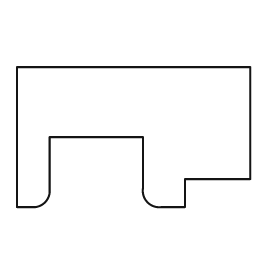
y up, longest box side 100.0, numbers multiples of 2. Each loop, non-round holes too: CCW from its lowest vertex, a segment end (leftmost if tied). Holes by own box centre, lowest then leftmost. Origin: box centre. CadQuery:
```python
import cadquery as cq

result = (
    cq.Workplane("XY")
    .moveTo(-50.0, -30.0)
    .lineTo(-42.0, -30.0)
    .threePointArc((-38.0, -28.0), (-36.0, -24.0))
    .lineTo(-36.0, 0.0)
    .lineTo(4.0, 0.0)
    .lineTo(4.0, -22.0)
    .threePointArc((6.0, -28.0), (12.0, -30.0))
    .lineTo(22.0, -30.0)
    .lineTo(22.0, -18.0)
    .lineTo(50.0, -18.0)
    .lineTo(50.0, 30.0)
    .lineTo(-50.0, 30.0)
    .close()
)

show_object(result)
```